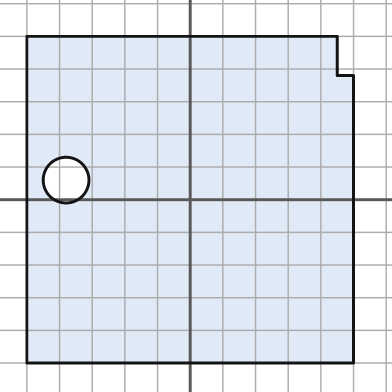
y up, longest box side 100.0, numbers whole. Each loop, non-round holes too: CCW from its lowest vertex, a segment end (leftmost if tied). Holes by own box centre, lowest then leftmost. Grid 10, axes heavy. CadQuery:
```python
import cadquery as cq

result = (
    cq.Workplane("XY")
    .moveTo(-50.0, -50.0)
    .lineTo(50.0, -50.0)
    .lineTo(50.0, 38.0)
    .lineTo(45.0, 38.0)
    .lineTo(45.0, 50.0)
    .lineTo(-50.0, 50.0)
    .close()
    .moveTo(-38.0, 6.0)
    .circle(7.0)
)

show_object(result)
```